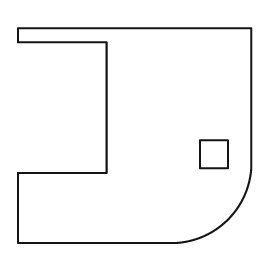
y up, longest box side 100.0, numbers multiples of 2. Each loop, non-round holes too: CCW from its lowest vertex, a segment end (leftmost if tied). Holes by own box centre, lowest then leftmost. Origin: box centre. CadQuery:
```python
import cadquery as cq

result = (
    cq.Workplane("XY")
    .moveTo(-50.0, -46.0)
    .lineTo(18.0, -46.0)
    .threePointArc((40.0, -36.0), (50.0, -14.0))
    .lineTo(50.0, 46.0)
    .lineTo(-50.0, 46.0)
    .lineTo(-50.0, 40.0)
    .lineTo(-12.0, 40.0)
    .lineTo(-12.0, -16.0)
    .lineTo(-50.0, -16.0)
    .close()
    .moveTo(28.0, -14.0)
    .lineTo(40.0, -14.0)
    .lineTo(40.0, -2.0)
    .lineTo(28.0, -2.0)
    .close()
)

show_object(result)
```